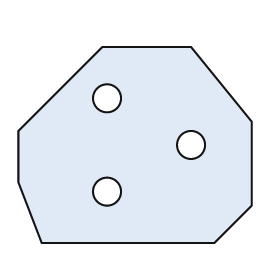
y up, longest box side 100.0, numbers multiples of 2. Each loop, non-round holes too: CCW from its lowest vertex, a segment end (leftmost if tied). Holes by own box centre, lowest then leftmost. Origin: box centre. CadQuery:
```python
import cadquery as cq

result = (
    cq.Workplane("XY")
    .moveTo(-40.0, -42.0)
    .lineTo(34.0, -42.0)
    .lineTo(50.0, -26.0)
    .lineTo(50.0, 10.0)
    .lineTo(24.0, 42.0)
    .lineTo(-14.0, 42.0)
    .lineTo(-50.0, 6.0)
    .lineTo(-50.0, -16.0)
    .close()
    .moveTo(-12.0, -20.0)
    .circle(6.0)
    .moveTo(24.0, 0.0)
    .circle(6.0)
    .moveTo(-12.0, 20.0)
    .circle(6.0)
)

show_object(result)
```